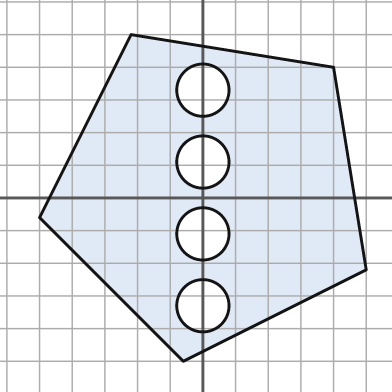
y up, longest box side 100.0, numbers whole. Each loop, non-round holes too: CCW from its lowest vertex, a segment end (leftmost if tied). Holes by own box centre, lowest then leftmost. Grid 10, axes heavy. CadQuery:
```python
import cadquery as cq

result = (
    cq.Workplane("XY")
    .moveTo(-6.0, -50.0)
    .lineTo(50.0, -22.0)
    .lineTo(40.0, 40.0)
    .lineTo(-22.0, 50.0)
    .lineTo(-50.0, -6.0)
    .close()
    .moveTo(0.0, -33.0)
    .circle(8.0)
    .moveTo(0.0, -11.0)
    .circle(8.0)
    .moveTo(0.0, 11.0)
    .circle(8.0)
    .moveTo(0.0, 33.0)
    .circle(8.0)
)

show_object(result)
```